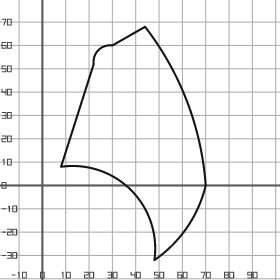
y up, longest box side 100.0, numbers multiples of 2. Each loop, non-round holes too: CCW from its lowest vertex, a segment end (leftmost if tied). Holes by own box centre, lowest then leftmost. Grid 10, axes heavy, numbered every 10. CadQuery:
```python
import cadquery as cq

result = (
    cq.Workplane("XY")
    .moveTo(48.0, -32.0)
    .threePointArc((62.0, -18.0), (70.0, 0.0))
    .threePointArc((62.0, 36.0), (44.0, 68.0))
    .lineTo(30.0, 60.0)
    .threePointArc((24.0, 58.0), (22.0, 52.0))
    .lineTo(8.0, 8.0)
    .threePointArc((38.0, -2.0), (48.0, -32.0))
    .close()
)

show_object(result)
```